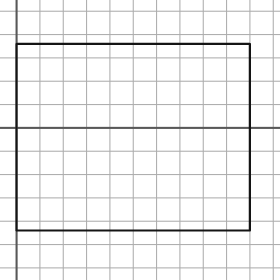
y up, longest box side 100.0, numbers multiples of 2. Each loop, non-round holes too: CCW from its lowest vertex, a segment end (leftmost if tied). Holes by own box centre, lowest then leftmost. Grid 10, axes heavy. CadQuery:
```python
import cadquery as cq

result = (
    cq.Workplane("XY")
    .moveTo(0.0, -44.0)
    .lineTo(100.0, -44.0)
    .lineTo(100.0, 36.0)
    .lineTo(0.0, 36.0)
    .close()
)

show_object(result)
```